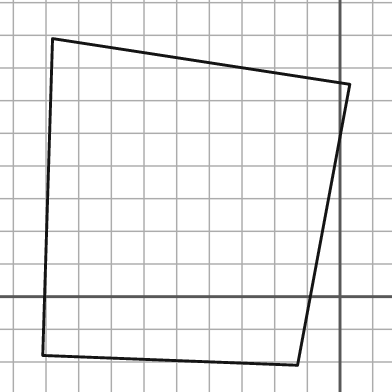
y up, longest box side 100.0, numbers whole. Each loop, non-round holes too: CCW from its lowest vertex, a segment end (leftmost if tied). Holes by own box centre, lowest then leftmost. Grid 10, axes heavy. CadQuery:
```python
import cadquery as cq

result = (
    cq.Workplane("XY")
    .moveTo(-13.0, -21.0)
    .lineTo(3.0, 65.0)
    .lineTo(-88.0, 79.0)
    .lineTo(-91.0, -18.0)
    .close()
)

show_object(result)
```